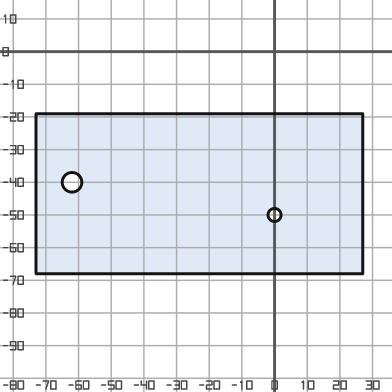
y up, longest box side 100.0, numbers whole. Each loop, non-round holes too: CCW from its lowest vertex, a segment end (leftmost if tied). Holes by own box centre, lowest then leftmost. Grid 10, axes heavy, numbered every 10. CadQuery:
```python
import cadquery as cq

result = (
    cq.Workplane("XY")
    .moveTo(-73.0, -68.0)
    .lineTo(27.0, -68.0)
    .lineTo(27.0, -19.0)
    .lineTo(-73.0, -19.0)
    .close()
    .moveTo(0.0, -50.0)
    .circle(2.0)
    .moveTo(-62.0, -40.0)
    .circle(3.0)
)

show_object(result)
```